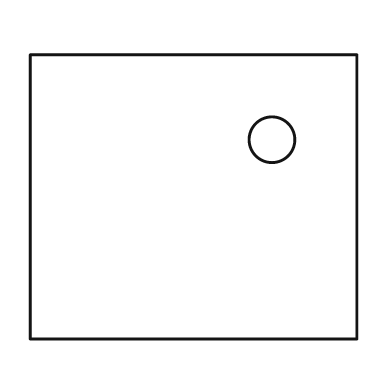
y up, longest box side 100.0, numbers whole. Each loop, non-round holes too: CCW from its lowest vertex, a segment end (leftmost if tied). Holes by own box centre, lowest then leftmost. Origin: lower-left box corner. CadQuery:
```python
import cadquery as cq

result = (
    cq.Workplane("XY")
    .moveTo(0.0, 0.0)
    .lineTo(100.0, 0.0)
    .lineTo(100.0, 87.0)
    .lineTo(0.0, 87.0)
    .close()
    .moveTo(74.0, 61.0)
    .circle(7.0)
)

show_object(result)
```